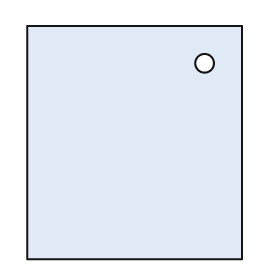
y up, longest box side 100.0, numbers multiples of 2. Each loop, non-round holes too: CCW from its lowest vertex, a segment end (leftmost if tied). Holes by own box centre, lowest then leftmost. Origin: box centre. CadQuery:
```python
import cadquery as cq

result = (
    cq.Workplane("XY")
    .moveTo(-46.0, -50.0)
    .lineTo(46.0, -50.0)
    .lineTo(46.0, 50.0)
    .lineTo(-46.0, 50.0)
    .close()
    .moveTo(30.0, 34.0)
    .circle(4.0)
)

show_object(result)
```